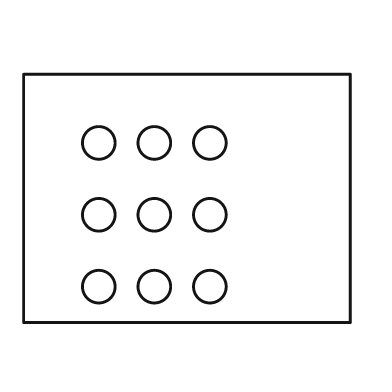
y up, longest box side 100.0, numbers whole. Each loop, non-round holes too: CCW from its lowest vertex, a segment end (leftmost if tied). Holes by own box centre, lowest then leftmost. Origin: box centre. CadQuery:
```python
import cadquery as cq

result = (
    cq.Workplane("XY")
    .moveTo(-50.0, -38.0)
    .lineTo(50.0, -38.0)
    .lineTo(50.0, 38.0)
    .lineTo(-50.0, 38.0)
    .close()
    .moveTo(-27.0, -27.0)
    .circle(5.0)
    .moveTo(-10.0, -27.0)
    .circle(5.0)
    .moveTo(7.0, -27.0)
    .circle(5.0)
    .moveTo(-27.0, -5.0)
    .circle(5.0)
    .moveTo(-10.0, -5.0)
    .circle(5.0)
    .moveTo(7.0, -5.0)
    .circle(5.0)
    .moveTo(-27.0, 17.0)
    .circle(5.0)
    .moveTo(-10.0, 17.0)
    .circle(5.0)
    .moveTo(7.0, 17.0)
    .circle(5.0)
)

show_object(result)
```